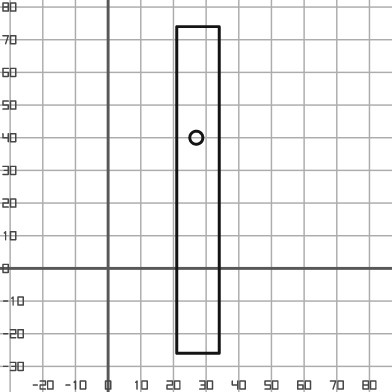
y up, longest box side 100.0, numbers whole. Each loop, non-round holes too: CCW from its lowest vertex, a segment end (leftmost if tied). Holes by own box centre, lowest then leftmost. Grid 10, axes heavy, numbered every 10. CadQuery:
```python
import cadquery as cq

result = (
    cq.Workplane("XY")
    .moveTo(21.0, -26.0)
    .lineTo(34.0, -26.0)
    .lineTo(34.0, 74.0)
    .lineTo(21.0, 74.0)
    .close()
    .moveTo(27.0, 40.0)
    .circle(2.0)
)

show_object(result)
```